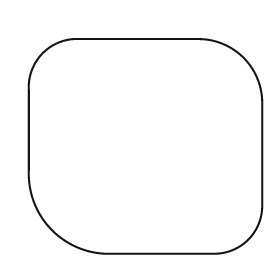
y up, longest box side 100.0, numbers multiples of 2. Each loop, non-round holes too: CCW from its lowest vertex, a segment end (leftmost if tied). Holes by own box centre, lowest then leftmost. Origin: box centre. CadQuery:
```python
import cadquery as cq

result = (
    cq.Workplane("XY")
    .moveTo(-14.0, -46.0)
    .lineTo(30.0, -46.0)
    .threePointArc((44.0, -40.0), (50.0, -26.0))
    .lineTo(50.0, 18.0)
    .threePointArc((42.0, 38.0), (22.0, 46.0))
    .lineTo(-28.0, 46.0)
    .threePointArc((-44.0, 40.0), (-50.0, 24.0))
    .lineTo(-50.0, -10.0)
    .threePointArc((-40.0, -36.0), (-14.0, -46.0))
    .close()
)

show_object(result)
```